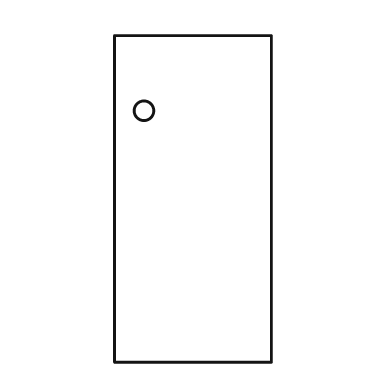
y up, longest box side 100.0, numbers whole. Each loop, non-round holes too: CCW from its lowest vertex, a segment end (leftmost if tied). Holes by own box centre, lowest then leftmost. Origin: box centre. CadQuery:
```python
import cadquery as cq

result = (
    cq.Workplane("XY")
    .moveTo(-24.0, -50.0)
    .lineTo(24.0, -50.0)
    .lineTo(24.0, 50.0)
    .lineTo(-24.0, 50.0)
    .close()
    .moveTo(-15.0, 27.0)
    .circle(3.0)
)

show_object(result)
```